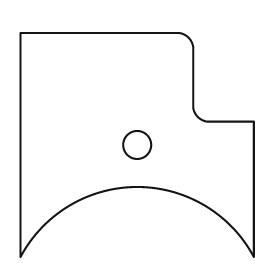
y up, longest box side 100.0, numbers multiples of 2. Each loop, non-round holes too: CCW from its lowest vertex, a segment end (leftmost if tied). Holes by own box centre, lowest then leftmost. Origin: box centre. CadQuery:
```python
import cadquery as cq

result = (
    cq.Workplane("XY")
    .moveTo(-50.0, -48.0)
    .threePointArc((0.0, -18.0), (50.0, -48.0))
    .lineTo(50.0, 10.0)
    .lineTo(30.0, 10.0)
    .threePointArc((26.0, 12.0), (24.0, 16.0))
    .lineTo(24.0, 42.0)
    .threePointArc((22.0, 46.0), (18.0, 48.0))
    .lineTo(-50.0, 48.0)
    .close()
    .moveTo(0.0, 0.0)
    .circle(6.0)
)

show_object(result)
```